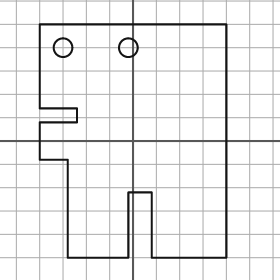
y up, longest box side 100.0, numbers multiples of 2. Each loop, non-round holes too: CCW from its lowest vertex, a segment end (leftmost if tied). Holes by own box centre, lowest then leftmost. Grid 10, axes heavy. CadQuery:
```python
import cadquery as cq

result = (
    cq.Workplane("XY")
    .moveTo(-28.0, -50.0)
    .lineTo(-2.0, -50.0)
    .lineTo(-2.0, -22.0)
    .lineTo(8.0, -22.0)
    .lineTo(8.0, -50.0)
    .lineTo(40.0, -50.0)
    .lineTo(40.0, 50.0)
    .lineTo(-40.0, 50.0)
    .lineTo(-40.0, 14.0)
    .lineTo(-24.0, 14.0)
    .lineTo(-24.0, 8.0)
    .lineTo(-40.0, 8.0)
    .lineTo(-40.0, -8.0)
    .lineTo(-28.0, -8.0)
    .close()
    .moveTo(-30.0, 40.0)
    .circle(4.0)
    .moveTo(-2.0, 40.0)
    .circle(4.0)
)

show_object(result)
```